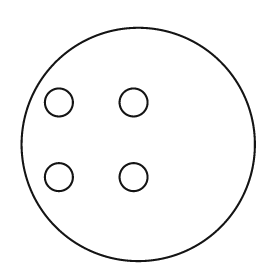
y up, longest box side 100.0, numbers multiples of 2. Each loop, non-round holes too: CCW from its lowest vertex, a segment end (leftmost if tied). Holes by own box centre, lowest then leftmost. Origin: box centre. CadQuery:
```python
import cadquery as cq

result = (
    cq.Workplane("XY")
    .moveTo(0.0, 0.0)
    .circle(50.0)
    .moveTo(-34.0, -14.0)
    .circle(6.0)
    .moveTo(-2.0, -14.0)
    .circle(6.0)
    .moveTo(-34.0, 18.0)
    .circle(6.0)
    .moveTo(-2.0, 18.0)
    .circle(6.0)
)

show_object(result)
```